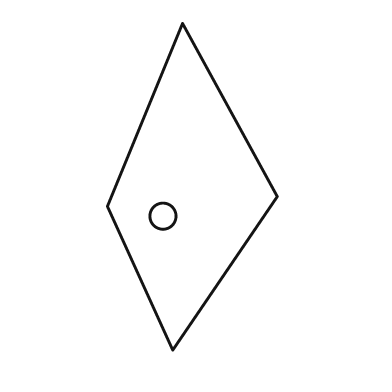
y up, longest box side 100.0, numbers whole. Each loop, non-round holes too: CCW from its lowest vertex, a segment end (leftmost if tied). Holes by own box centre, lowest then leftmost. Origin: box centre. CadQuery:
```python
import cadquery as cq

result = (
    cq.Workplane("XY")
    .moveTo(-6.0, -50.0)
    .lineTo(26.0, -3.0)
    .lineTo(-3.0, 50.0)
    .lineTo(-26.0, -6.0)
    .close()
    .moveTo(-9.0, -9.0)
    .circle(4.0)
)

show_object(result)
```